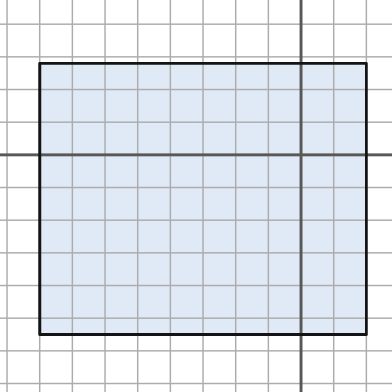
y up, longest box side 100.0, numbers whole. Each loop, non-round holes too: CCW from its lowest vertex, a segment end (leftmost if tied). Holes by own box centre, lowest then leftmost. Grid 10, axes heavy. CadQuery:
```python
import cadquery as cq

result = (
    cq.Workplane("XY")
    .moveTo(-80.0, -55.0)
    .lineTo(20.0, -55.0)
    .lineTo(20.0, 28.0)
    .lineTo(-80.0, 28.0)
    .close()
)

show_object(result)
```